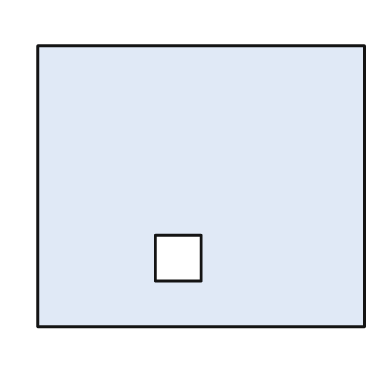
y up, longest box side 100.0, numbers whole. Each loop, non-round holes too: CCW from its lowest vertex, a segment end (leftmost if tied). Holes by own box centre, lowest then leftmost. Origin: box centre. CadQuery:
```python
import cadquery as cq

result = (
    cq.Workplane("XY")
    .moveTo(-50.0, -43.0)
    .lineTo(50.0, -43.0)
    .lineTo(50.0, 43.0)
    .lineTo(-50.0, 43.0)
    .close()
    .moveTo(-14.0, -29.0)
    .lineTo(0.0, -29.0)
    .lineTo(0.0, -15.0)
    .lineTo(-14.0, -15.0)
    .close()
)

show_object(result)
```